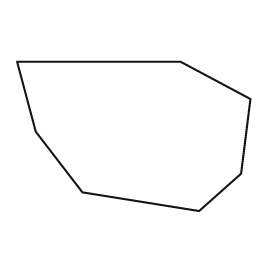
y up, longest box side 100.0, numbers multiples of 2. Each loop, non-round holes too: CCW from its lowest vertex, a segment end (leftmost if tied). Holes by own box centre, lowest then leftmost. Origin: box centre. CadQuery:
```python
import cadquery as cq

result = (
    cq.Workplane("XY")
    .moveTo(28.0, -32.0)
    .lineTo(46.0, -16.0)
    .lineTo(50.0, 16.0)
    .lineTo(20.0, 32.0)
    .lineTo(-50.0, 32.0)
    .lineTo(-42.0, 2.0)
    .lineTo(-22.0, -24.0)
    .close()
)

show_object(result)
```